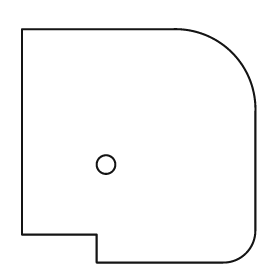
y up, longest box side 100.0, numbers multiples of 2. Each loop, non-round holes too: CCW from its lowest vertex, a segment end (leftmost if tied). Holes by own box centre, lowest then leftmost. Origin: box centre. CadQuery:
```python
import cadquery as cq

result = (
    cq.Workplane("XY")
    .moveTo(-18.0, -50.0)
    .lineTo(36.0, -50.0)
    .threePointArc((46.0, -46.0), (50.0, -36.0))
    .lineTo(50.0, 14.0)
    .threePointArc((40.0, 40.0), (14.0, 50.0))
    .lineTo(-50.0, 50.0)
    .lineTo(-50.0, -38.0)
    .lineTo(-18.0, -38.0)
    .close()
    .moveTo(-14.0, -8.0)
    .circle(4.0)
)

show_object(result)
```